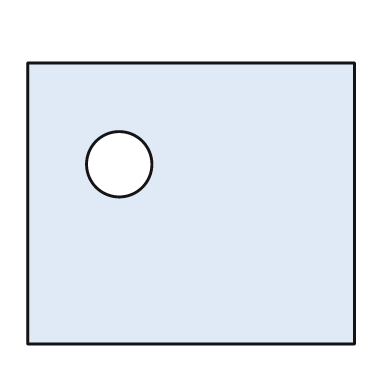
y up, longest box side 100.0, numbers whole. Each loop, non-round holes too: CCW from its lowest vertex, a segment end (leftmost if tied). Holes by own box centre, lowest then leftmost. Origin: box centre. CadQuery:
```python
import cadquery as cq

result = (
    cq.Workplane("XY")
    .moveTo(-50.0, -43.0)
    .lineTo(50.0, -43.0)
    .lineTo(50.0, 43.0)
    .lineTo(-50.0, 43.0)
    .close()
    .moveTo(-22.0, 12.0)
    .circle(10.0)
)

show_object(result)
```